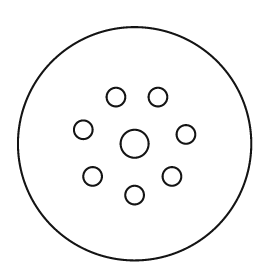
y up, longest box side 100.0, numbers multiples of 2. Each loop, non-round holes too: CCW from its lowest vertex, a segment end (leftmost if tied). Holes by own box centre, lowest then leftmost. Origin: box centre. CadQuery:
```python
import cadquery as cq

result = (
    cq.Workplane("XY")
    .moveTo(0.0, 0.0)
    .circle(50.0)
    .moveTo(0.0, -22.0)
    .circle(4.0)
    .moveTo(-18.0, -14.0)
    .circle(4.0)
    .moveTo(16.0, -14.0)
    .circle(4.0)
    .moveTo(0.0, 0.0)
    .circle(6.0)
    .moveTo(22.0, 4.0)
    .circle(4.0)
    .moveTo(-22.0, 6.0)
    .circle(4.0)
    .moveTo(-8.0, 20.0)
    .circle(4.0)
    .moveTo(10.0, 20.0)
    .circle(4.0)
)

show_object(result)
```